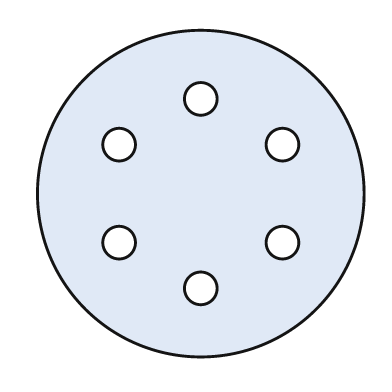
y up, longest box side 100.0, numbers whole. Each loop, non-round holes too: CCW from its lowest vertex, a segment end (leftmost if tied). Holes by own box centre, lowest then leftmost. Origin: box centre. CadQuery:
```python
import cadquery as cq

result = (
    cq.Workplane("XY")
    .moveTo(0.0, 0.0)
    .circle(50.0)
    .moveTo(0.0, -29.0)
    .circle(5.0)
    .moveTo(-25.0, -15.0)
    .circle(5.0)
    .moveTo(25.0, -15.0)
    .circle(5.0)
    .moveTo(-25.0, 15.0)
    .circle(5.0)
    .moveTo(25.0, 15.0)
    .circle(5.0)
    .moveTo(0.0, 29.0)
    .circle(5.0)
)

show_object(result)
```